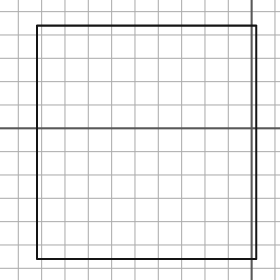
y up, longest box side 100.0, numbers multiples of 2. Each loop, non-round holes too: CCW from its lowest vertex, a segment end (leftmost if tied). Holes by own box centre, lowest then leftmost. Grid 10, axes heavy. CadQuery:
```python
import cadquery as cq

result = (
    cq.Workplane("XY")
    .moveTo(-92.0, -56.0)
    .lineTo(2.0, -56.0)
    .lineTo(2.0, 44.0)
    .lineTo(-92.0, 44.0)
    .close()
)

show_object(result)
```